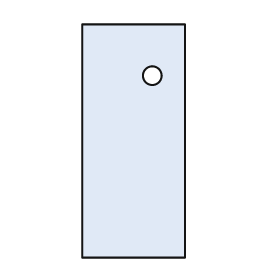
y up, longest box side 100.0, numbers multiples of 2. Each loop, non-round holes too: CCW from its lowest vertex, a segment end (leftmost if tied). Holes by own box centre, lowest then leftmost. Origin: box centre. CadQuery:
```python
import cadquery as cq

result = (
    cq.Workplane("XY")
    .moveTo(-22.0, -50.0)
    .lineTo(22.0, -50.0)
    .lineTo(22.0, 50.0)
    .lineTo(-22.0, 50.0)
    .close()
    .moveTo(8.0, 28.0)
    .circle(4.0)
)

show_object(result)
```